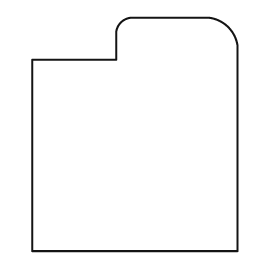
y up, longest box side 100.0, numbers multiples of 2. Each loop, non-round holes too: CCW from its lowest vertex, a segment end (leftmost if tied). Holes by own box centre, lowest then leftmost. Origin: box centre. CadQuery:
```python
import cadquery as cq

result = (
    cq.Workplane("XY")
    .moveTo(-44.0, -50.0)
    .lineTo(44.0, -50.0)
    .lineTo(44.0, 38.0)
    .threePointArc((40.0, 46.0), (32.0, 50.0))
    .lineTo(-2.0, 50.0)
    .threePointArc((-6.0, 48.0), (-8.0, 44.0))
    .lineTo(-8.0, 32.0)
    .lineTo(-44.0, 32.0)
    .close()
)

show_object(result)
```